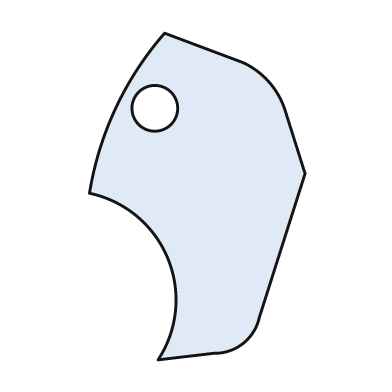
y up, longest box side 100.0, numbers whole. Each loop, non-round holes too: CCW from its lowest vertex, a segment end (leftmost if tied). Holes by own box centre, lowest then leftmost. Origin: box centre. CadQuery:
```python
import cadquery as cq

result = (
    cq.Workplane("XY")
    .moveTo(-12.0, -50.0)
    .lineTo(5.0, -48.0)
    .threePointArc((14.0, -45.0), (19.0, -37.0))
    .lineTo(33.0, 7.0)
    .lineTo(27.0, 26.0)
    .threePointArc((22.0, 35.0), (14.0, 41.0))
    .lineTo(-10.0, 50.0)
    .threePointArc((-25.0, 27.0), (-33.0, 1.0))
    .threePointArc((-9.0, -19.0), (-12.0, -50.0))
    .close()
    .moveTo(-13.0, 27.0)
    .circle(7.0)
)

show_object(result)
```